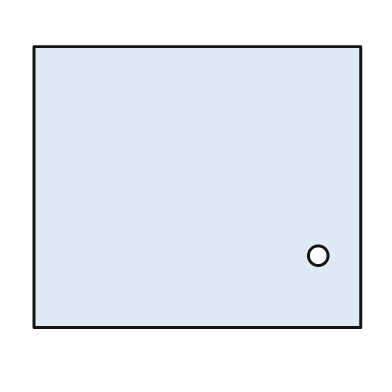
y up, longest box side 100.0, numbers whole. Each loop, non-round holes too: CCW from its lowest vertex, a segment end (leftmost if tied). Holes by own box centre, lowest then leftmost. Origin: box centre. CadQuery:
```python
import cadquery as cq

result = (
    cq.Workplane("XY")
    .moveTo(-50.0, -43.0)
    .lineTo(50.0, -43.0)
    .lineTo(50.0, 43.0)
    .lineTo(-50.0, 43.0)
    .close()
    .moveTo(37.0, -21.0)
    .circle(3.0)
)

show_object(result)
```